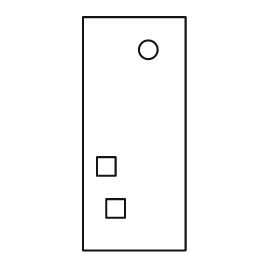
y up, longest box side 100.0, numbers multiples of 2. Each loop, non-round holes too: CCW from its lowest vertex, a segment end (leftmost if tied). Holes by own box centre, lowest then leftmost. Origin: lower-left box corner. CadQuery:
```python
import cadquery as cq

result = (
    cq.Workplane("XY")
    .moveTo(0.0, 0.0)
    .lineTo(44.0, 0.0)
    .lineTo(44.0, 100.0)
    .lineTo(0.0, 100.0)
    .close()
    .moveTo(10.0, 14.0)
    .lineTo(18.0, 14.0)
    .lineTo(18.0, 22.0)
    .lineTo(10.0, 22.0)
    .close()
    .moveTo(6.0, 32.0)
    .lineTo(14.0, 32.0)
    .lineTo(14.0, 40.0)
    .lineTo(6.0, 40.0)
    .close()
    .moveTo(28.0, 86.0)
    .circle(4.0)
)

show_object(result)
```